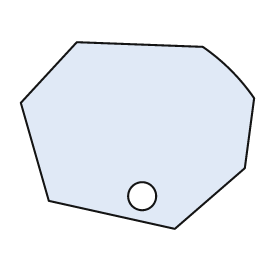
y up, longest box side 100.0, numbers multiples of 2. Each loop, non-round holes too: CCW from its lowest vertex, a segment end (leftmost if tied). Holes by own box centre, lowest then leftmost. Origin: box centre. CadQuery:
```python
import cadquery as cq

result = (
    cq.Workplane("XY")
    .moveTo(16.0, -40.0)
    .lineTo(46.0, -14.0)
    .lineTo(50.0, 16.0)
    .threePointArc((40.0, 28.0), (28.0, 38.0))
    .lineTo(-26.0, 40.0)
    .lineTo(-50.0, 14.0)
    .lineTo(-38.0, -28.0)
    .close()
    .moveTo(2.0, -26.0)
    .circle(6.0)
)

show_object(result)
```